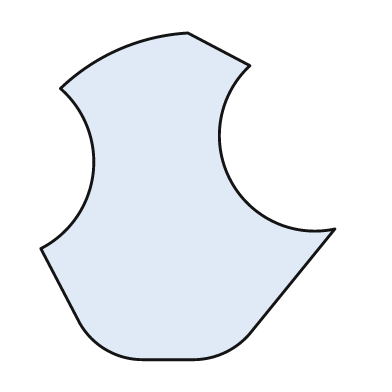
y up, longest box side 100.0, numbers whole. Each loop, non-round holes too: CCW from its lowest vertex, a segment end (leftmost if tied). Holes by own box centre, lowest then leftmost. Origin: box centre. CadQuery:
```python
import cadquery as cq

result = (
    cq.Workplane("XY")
    .moveTo(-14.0, -50.0)
    .lineTo(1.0, -50.0)
    .threePointArc((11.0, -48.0), (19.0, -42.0))
    .lineTo(45.0, -10.0)
    .threePointArc((13.0, 5.0), (19.0, 40.0))
    .lineTo(0.0, 50.0)
    .threePointArc((-21.0, 45.0), (-39.0, 33.0))
    .threePointArc((-29.0, 7.0), (-45.0, -16.0))
    .lineTo(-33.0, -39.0)
    .threePointArc((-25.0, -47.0), (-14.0, -50.0))
    .close()
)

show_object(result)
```